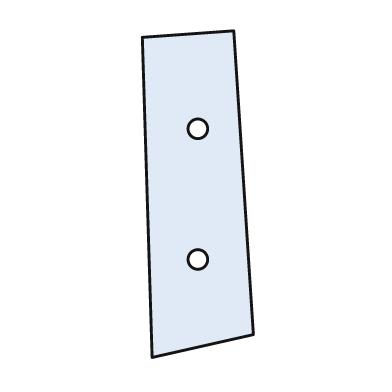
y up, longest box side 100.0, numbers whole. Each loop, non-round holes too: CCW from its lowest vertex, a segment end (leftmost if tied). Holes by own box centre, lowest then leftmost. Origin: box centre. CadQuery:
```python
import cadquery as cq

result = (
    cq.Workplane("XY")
    .moveTo(-14.0, -50.0)
    .lineTo(17.0, -43.0)
    .lineTo(11.0, 50.0)
    .lineTo(-17.0, 48.0)
    .close()
    .moveTo(0.0, -20.0)
    .circle(3.0)
    .moveTo(0.0, 20.0)
    .circle(3.0)
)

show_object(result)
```